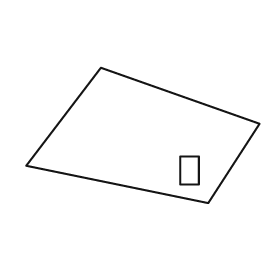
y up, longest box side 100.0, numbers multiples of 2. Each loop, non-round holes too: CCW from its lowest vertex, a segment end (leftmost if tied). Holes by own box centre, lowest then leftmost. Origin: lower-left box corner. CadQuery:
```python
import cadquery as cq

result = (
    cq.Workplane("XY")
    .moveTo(78.0, 0.0)
    .lineTo(100.0, 34.0)
    .lineTo(32.0, 58.0)
    .lineTo(0.0, 16.0)
    .close()
    .moveTo(66.0, 8.0)
    .lineTo(74.0, 8.0)
    .lineTo(74.0, 20.0)
    .lineTo(66.0, 20.0)
    .close()
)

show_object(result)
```